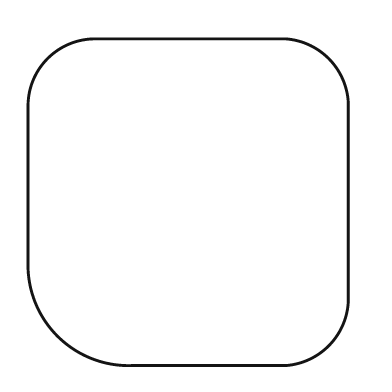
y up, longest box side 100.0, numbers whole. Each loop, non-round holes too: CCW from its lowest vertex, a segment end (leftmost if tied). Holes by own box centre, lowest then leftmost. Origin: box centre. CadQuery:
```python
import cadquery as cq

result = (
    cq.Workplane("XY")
    .moveTo(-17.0, -50.0)
    .lineTo(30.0, -50.0)
    .threePointArc((43.0, -44.0), (49.0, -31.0))
    .lineTo(49.0, 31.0)
    .threePointArc((43.0, 44.0), (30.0, 50.0))
    .lineTo(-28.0, 50.0)
    .threePointArc((-43.0, 44.0), (-49.0, 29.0))
    .lineTo(-49.0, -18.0)
    .threePointArc((-40.0, -41.0), (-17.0, -50.0))
    .close()
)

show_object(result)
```